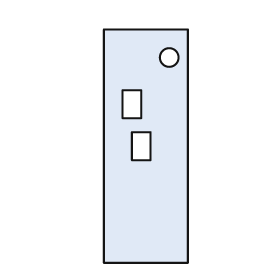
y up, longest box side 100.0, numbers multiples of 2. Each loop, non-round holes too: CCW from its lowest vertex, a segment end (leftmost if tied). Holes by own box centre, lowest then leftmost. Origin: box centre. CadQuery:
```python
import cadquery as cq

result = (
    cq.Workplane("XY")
    .moveTo(-18.0, -50.0)
    .lineTo(18.0, -50.0)
    .lineTo(18.0, 50.0)
    .lineTo(-18.0, 50.0)
    .close()
    .moveTo(-6.0, -6.0)
    .lineTo(2.0, -6.0)
    .lineTo(2.0, 6.0)
    .lineTo(-6.0, 6.0)
    .close()
    .moveTo(-10.0, 12.0)
    .lineTo(-2.0, 12.0)
    .lineTo(-2.0, 24.0)
    .lineTo(-10.0, 24.0)
    .close()
    .moveTo(10.0, 38.0)
    .circle(4.0)
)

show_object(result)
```